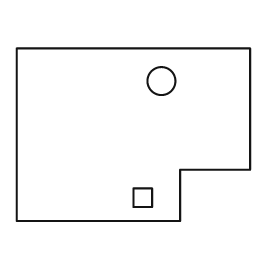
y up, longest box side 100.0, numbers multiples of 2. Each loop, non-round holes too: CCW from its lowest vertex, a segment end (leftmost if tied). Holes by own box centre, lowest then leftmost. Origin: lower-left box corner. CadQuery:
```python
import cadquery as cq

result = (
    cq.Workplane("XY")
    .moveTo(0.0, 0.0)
    .lineTo(70.0, 0.0)
    .lineTo(70.0, 22.0)
    .lineTo(100.0, 22.0)
    .lineTo(100.0, 74.0)
    .lineTo(0.0, 74.0)
    .close()
    .moveTo(50.0, 6.0)
    .lineTo(58.0, 6.0)
    .lineTo(58.0, 14.0)
    .lineTo(50.0, 14.0)
    .close()
    .moveTo(62.0, 60.0)
    .circle(6.0)
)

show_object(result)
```